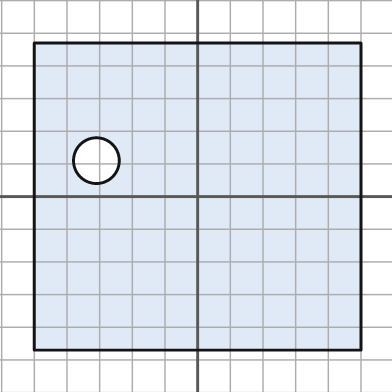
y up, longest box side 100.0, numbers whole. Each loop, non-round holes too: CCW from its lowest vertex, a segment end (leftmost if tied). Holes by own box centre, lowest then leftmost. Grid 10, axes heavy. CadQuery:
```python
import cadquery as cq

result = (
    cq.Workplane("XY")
    .moveTo(-50.0, -47.0)
    .lineTo(50.0, -47.0)
    .lineTo(50.0, 47.0)
    .lineTo(-50.0, 47.0)
    .close()
    .moveTo(-31.0, 11.0)
    .circle(7.0)
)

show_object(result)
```